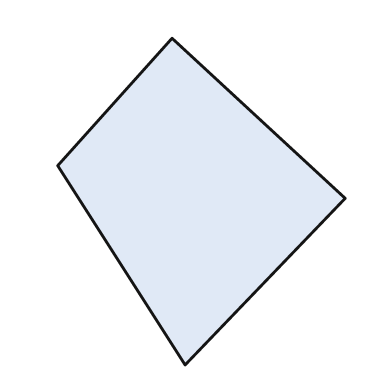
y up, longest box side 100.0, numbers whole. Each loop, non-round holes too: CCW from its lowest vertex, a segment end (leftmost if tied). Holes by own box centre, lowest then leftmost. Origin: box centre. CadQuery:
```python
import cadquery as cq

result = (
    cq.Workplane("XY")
    .moveTo(-5.0, -50.0)
    .lineTo(44.0, 1.0)
    .lineTo(-9.0, 50.0)
    .lineTo(-44.0, 11.0)
    .close()
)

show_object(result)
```